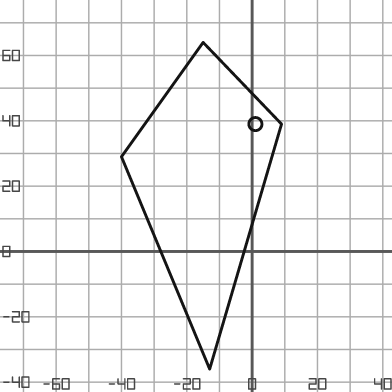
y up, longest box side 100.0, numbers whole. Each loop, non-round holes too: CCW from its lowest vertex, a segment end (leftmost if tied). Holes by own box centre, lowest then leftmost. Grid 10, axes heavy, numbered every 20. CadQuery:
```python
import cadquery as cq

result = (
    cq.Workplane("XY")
    .moveTo(-13.0, -36.0)
    .lineTo(9.0, 39.0)
    .lineTo(-15.0, 64.0)
    .lineTo(-40.0, 29.0)
    .close()
    .moveTo(1.0, 39.0)
    .circle(2.0)
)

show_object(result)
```